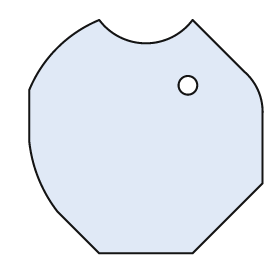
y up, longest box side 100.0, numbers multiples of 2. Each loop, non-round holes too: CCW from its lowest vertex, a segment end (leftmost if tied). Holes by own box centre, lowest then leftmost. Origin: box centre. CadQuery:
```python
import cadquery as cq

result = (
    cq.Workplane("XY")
    .moveTo(-20.0, -50.0)
    .lineTo(20.0, -50.0)
    .lineTo(50.0, -20.0)
    .lineTo(50.0, 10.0)
    .threePointArc((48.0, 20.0), (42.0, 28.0))
    .lineTo(20.0, 50.0)
    .threePointArc((0.0, 40.0), (-20.0, 50.0))
    .threePointArc((-38.0, 38.0), (-50.0, 20.0))
    .lineTo(-50.0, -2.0)
    .threePointArc((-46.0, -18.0), (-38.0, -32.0))
    .close()
    .moveTo(18.0, 22.0)
    .circle(4.0)
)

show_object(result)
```